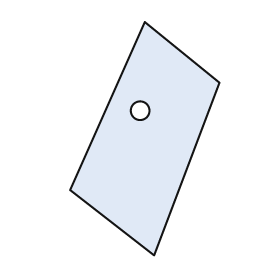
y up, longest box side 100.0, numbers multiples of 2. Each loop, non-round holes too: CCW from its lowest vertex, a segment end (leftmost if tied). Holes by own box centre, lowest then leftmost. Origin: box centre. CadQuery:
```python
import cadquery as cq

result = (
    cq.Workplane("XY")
    .moveTo(4.0, -50.0)
    .lineTo(32.0, 24.0)
    .lineTo(0.0, 50.0)
    .lineTo(-32.0, -22.0)
    .close()
    .moveTo(-2.0, 12.0)
    .circle(4.0)
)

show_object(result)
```